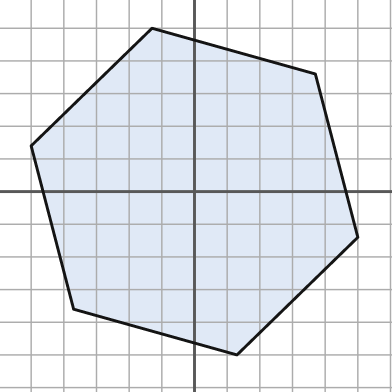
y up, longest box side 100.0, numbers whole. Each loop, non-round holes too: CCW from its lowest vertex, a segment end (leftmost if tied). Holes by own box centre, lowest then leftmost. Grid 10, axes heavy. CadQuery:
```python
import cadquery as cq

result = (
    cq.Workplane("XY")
    .moveTo(13.0, -50.0)
    .lineTo(50.0, -14.0)
    .lineTo(37.0, 36.0)
    .lineTo(-13.0, 50.0)
    .lineTo(-50.0, 14.0)
    .lineTo(-37.0, -36.0)
    .close()
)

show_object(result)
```